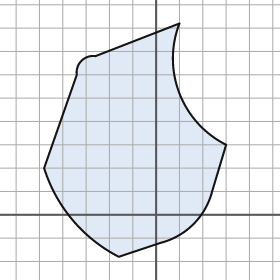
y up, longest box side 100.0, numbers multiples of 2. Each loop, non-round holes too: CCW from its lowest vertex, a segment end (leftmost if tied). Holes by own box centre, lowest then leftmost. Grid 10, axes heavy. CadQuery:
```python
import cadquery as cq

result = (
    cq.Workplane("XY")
    .moveTo(-16.0, -18.0)
    .lineTo(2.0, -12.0)
    .threePointArc((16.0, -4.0), (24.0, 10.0))
    .lineTo(30.0, 30.0)
    .threePointArc((10.0, 52.0), (10.0, 82.0))
    .lineTo(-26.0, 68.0)
    .threePointArc((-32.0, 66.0), (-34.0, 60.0))
    .lineTo(-48.0, 20.0)
    .threePointArc((-36.0, -2.0), (-16.0, -18.0))
    .close()
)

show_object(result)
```